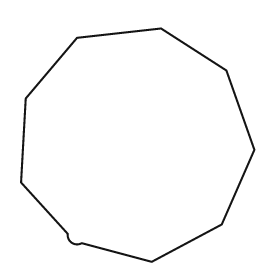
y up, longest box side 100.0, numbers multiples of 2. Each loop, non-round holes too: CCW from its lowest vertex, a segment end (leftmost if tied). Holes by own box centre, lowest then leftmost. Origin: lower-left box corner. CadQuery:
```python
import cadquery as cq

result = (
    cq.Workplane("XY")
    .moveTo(56.0, 0.0)
    .lineTo(86.0, 16.0)
    .lineTo(100.0, 48.0)
    .lineTo(88.0, 82.0)
    .lineTo(60.0, 100.0)
    .lineTo(24.0, 96.0)
    .lineTo(2.0, 70.0)
    .lineTo(0.0, 34.0)
    .lineTo(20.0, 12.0)
    .threePointArc((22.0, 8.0), (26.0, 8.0))
    .close()
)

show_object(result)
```